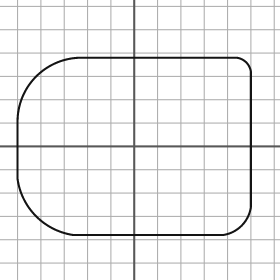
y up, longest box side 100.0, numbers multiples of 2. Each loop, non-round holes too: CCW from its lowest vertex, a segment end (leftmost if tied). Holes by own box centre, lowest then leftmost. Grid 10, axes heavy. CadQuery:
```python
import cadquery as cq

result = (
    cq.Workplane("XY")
    .moveTo(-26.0, -38.0)
    .lineTo(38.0, -38.0)
    .threePointArc((46.0, -34.0), (50.0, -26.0))
    .lineTo(50.0, 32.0)
    .threePointArc((48.0, 36.0), (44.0, 38.0))
    .lineTo(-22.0, 38.0)
    .threePointArc((-42.0, 30.0), (-50.0, 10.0))
    .lineTo(-50.0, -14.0)
    .threePointArc((-42.0, -30.0), (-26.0, -38.0))
    .close()
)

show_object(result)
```